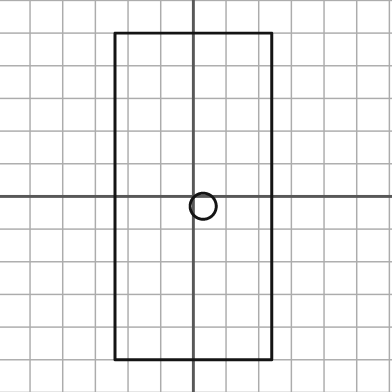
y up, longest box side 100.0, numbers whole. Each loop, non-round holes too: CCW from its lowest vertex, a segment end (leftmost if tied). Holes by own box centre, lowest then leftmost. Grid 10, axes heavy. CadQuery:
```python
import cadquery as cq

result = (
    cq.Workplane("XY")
    .moveTo(-24.0, -50.0)
    .lineTo(24.0, -50.0)
    .lineTo(24.0, 50.0)
    .lineTo(-24.0, 50.0)
    .close()
    .moveTo(3.0, -3.0)
    .circle(4.0)
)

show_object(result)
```